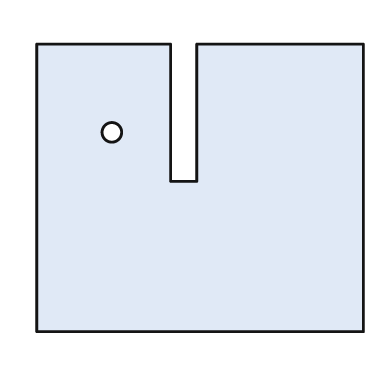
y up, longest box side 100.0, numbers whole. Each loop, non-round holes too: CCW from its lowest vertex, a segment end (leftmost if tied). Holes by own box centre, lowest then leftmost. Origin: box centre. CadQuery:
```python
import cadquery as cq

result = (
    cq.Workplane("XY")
    .moveTo(-50.0, -44.0)
    .lineTo(50.0, -44.0)
    .lineTo(50.0, 44.0)
    .lineTo(-1.0, 44.0)
    .lineTo(-1.0, 2.0)
    .lineTo(-9.0, 2.0)
    .lineTo(-9.0, 44.0)
    .lineTo(-50.0, 44.0)
    .close()
    .moveTo(-27.0, 17.0)
    .circle(3.0)
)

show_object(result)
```